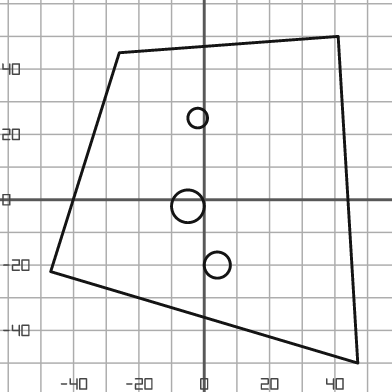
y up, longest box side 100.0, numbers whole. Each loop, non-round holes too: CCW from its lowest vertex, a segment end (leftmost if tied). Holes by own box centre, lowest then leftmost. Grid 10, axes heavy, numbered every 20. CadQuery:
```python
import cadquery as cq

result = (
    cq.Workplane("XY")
    .moveTo(47.0, -50.0)
    .lineTo(41.0, 50.0)
    .lineTo(-26.0, 45.0)
    .lineTo(-47.0, -22.0)
    .close()
    .moveTo(4.0, -20.0)
    .circle(4.0)
    .moveTo(-5.0, -2.0)
    .circle(5.0)
    .moveTo(-2.0, 25.0)
    .circle(3.0)
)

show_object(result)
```